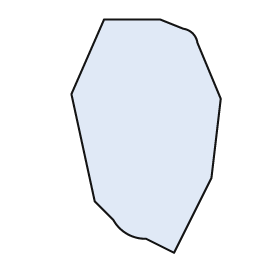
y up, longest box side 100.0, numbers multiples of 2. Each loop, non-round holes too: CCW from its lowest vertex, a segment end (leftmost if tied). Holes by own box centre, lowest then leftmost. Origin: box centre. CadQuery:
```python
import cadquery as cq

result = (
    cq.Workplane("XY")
    .moveTo(12.0, -50.0)
    .lineTo(28.0, -18.0)
    .lineTo(32.0, 16.0)
    .lineTo(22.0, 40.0)
    .threePointArc((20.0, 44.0), (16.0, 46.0))
    .lineTo(6.0, 50.0)
    .lineTo(-18.0, 50.0)
    .lineTo(-32.0, 18.0)
    .lineTo(-22.0, -28.0)
    .lineTo(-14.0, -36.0)
    .threePointArc((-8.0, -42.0), (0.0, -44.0))
    .close()
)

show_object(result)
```